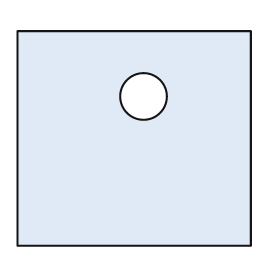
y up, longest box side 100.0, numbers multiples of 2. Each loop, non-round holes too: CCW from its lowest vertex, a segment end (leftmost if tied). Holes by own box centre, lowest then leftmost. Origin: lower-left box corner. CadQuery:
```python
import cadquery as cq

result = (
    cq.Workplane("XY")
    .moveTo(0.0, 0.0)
    .lineTo(100.0, 0.0)
    .lineTo(100.0, 92.0)
    .lineTo(0.0, 92.0)
    .close()
    .moveTo(54.0, 64.0)
    .circle(10.0)
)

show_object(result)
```